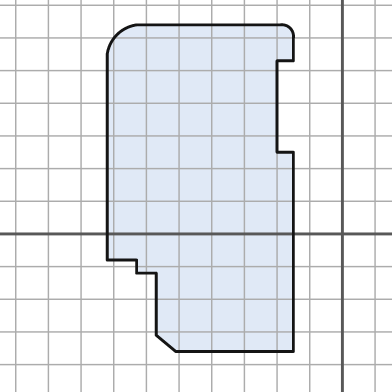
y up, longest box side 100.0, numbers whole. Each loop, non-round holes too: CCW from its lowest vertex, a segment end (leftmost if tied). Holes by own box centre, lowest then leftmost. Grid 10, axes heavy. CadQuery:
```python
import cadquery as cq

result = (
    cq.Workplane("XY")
    .moveTo(-51.0, -36.0)
    .lineTo(-15.0, -36.0)
    .lineTo(-15.0, 25.0)
    .lineTo(-20.0, 25.0)
    .lineTo(-20.0, 53.0)
    .lineTo(-15.0, 53.0)
    .lineTo(-15.0, 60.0)
    .threePointArc((-16.0, 63.0), (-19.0, 64.0))
    .lineTo(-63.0, 64.0)
    .threePointArc((-69.0, 61.0), (-72.0, 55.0))
    .lineTo(-72.0, -8.0)
    .lineTo(-63.0, -8.0)
    .lineTo(-63.0, -12.0)
    .lineTo(-57.0, -12.0)
    .lineTo(-57.0, -31.0)
    .close()
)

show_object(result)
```